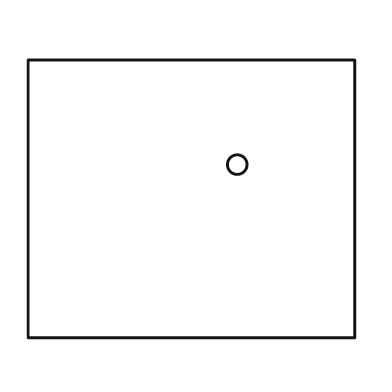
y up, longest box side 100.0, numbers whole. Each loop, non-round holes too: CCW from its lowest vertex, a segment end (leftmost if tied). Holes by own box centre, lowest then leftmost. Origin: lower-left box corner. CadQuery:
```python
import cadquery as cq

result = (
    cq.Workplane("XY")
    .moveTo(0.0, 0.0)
    .lineTo(100.0, 0.0)
    .lineTo(100.0, 85.0)
    .lineTo(0.0, 85.0)
    .close()
    .moveTo(64.0, 53.0)
    .circle(3.0)
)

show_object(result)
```